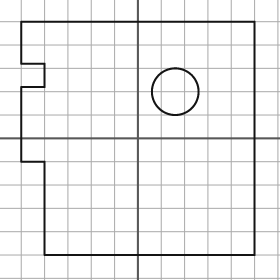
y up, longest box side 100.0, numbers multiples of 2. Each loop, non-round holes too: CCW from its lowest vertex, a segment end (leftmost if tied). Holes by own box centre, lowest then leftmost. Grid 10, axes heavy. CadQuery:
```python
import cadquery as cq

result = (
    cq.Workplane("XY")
    .moveTo(-40.0, -50.0)
    .lineTo(50.0, -50.0)
    .lineTo(50.0, 50.0)
    .lineTo(-50.0, 50.0)
    .lineTo(-50.0, 32.0)
    .lineTo(-40.0, 32.0)
    .lineTo(-40.0, 22.0)
    .lineTo(-50.0, 22.0)
    .lineTo(-50.0, -10.0)
    .lineTo(-40.0, -10.0)
    .close()
    .moveTo(16.0, 20.0)
    .circle(10.0)
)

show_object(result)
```